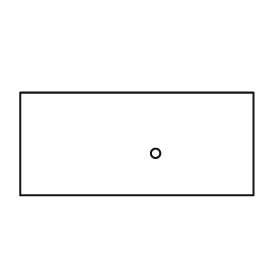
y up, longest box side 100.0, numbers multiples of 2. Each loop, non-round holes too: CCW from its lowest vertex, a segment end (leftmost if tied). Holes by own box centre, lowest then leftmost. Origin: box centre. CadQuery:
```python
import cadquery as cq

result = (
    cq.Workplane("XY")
    .moveTo(-50.0, -22.0)
    .lineTo(50.0, -22.0)
    .lineTo(50.0, 22.0)
    .lineTo(-50.0, 22.0)
    .close()
    .moveTo(8.0, -4.0)
    .circle(2.0)
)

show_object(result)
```